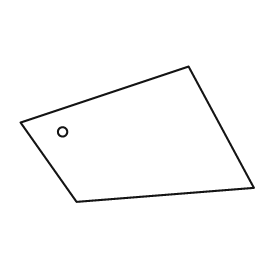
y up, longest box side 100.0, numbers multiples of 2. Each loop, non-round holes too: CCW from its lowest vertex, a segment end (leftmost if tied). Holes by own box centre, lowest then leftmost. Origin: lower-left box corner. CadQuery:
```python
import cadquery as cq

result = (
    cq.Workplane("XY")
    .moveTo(24.0, 0.0)
    .lineTo(100.0, 6.0)
    .lineTo(72.0, 58.0)
    .lineTo(0.0, 34.0)
    .close()
    .moveTo(18.0, 30.0)
    .circle(2.0)
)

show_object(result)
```